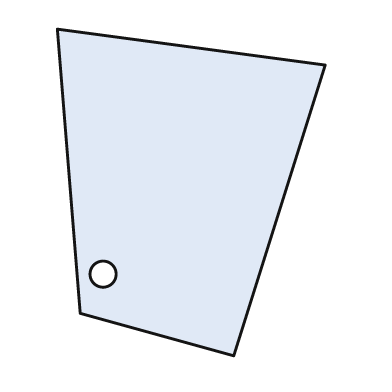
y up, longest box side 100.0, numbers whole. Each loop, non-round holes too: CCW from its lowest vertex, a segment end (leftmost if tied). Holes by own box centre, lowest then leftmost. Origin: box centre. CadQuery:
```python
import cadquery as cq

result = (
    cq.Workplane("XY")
    .moveTo(13.0, -50.0)
    .lineTo(41.0, 39.0)
    .lineTo(-41.0, 50.0)
    .lineTo(-34.0, -37.0)
    .close()
    .moveTo(-27.0, -25.0)
    .circle(4.0)
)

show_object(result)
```